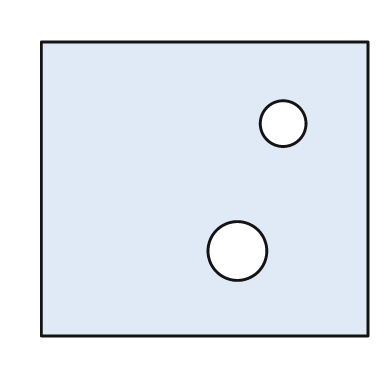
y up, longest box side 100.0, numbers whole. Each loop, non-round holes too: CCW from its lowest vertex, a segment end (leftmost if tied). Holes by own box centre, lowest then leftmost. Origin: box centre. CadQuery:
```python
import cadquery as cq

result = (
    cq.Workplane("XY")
    .moveTo(-50.0, -45.0)
    .lineTo(50.0, -45.0)
    .lineTo(50.0, 45.0)
    .lineTo(-50.0, 45.0)
    .close()
    .moveTo(10.0, -19.0)
    .circle(9.0)
    .moveTo(24.0, 20.0)
    .circle(7.0)
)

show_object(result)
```